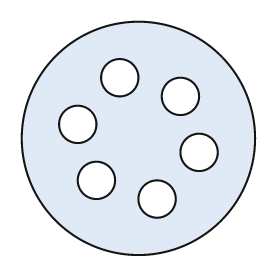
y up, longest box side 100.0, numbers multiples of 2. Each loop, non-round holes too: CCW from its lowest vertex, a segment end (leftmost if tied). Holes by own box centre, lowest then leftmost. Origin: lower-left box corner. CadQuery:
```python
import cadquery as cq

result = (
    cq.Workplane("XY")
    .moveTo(50.0, 50.0)
    .circle(50.0)
    .moveTo(58.0, 24.0)
    .circle(8.0)
    .moveTo(32.0, 32.0)
    .circle(8.0)
    .moveTo(76.0, 44.0)
    .circle(8.0)
    .moveTo(24.0, 56.0)
    .circle(8.0)
    .moveTo(68.0, 68.0)
    .circle(8.0)
    .moveTo(42.0, 76.0)
    .circle(8.0)
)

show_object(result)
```